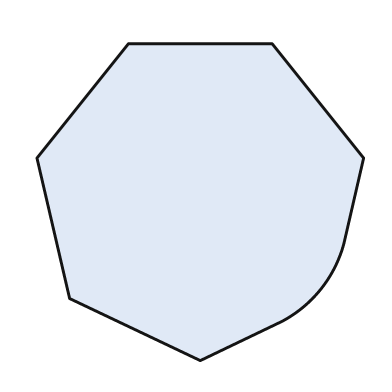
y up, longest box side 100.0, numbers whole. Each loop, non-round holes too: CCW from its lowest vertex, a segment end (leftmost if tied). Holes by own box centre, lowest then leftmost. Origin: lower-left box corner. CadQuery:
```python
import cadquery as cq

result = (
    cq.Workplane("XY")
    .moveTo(50.0, 0.0)
    .lineTo(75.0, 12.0)
    .threePointArc((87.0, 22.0), (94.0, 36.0))
    .lineTo(100.0, 62.0)
    .lineTo(72.0, 97.0)
    .lineTo(28.0, 97.0)
    .lineTo(0.0, 62.0)
    .lineTo(10.0, 19.0)
    .close()
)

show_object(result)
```